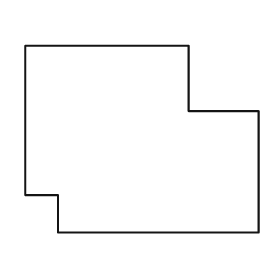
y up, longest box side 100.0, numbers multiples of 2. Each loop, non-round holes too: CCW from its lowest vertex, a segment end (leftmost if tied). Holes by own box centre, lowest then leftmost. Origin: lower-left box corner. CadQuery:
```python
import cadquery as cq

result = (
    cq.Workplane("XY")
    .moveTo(14.0, 0.0)
    .lineTo(100.0, 0.0)
    .lineTo(100.0, 52.0)
    .lineTo(70.0, 52.0)
    .lineTo(70.0, 80.0)
    .lineTo(0.0, 80.0)
    .lineTo(0.0, 16.0)
    .lineTo(14.0, 16.0)
    .close()
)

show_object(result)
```